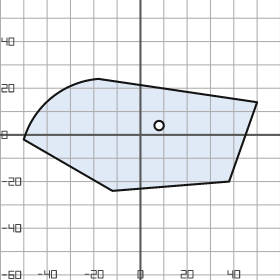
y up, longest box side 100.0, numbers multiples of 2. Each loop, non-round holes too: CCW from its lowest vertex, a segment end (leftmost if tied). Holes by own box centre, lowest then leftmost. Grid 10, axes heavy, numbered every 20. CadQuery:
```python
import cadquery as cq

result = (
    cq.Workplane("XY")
    .moveTo(-12.0, -24.0)
    .lineTo(38.0, -20.0)
    .lineTo(50.0, 14.0)
    .lineTo(-18.0, 24.0)
    .threePointArc((-38.0, 16.0), (-50.0, -2.0))
    .close()
    .moveTo(8.0, 4.0)
    .circle(2.0)
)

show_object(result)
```